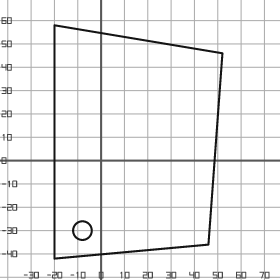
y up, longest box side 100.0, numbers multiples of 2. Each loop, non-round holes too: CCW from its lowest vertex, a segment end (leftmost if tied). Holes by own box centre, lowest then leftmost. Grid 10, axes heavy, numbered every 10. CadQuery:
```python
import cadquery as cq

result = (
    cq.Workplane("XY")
    .moveTo(-20.0, -42.0)
    .lineTo(46.0, -36.0)
    .lineTo(52.0, 46.0)
    .lineTo(-20.0, 58.0)
    .close()
    .moveTo(-8.0, -30.0)
    .circle(4.0)
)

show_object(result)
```